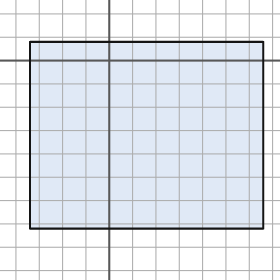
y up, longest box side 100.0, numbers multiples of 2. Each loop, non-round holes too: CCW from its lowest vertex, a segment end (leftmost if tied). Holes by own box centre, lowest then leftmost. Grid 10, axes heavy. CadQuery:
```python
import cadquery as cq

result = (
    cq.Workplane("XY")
    .moveTo(-34.0, -72.0)
    .lineTo(66.0, -72.0)
    .lineTo(66.0, 8.0)
    .lineTo(-34.0, 8.0)
    .close()
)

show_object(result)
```